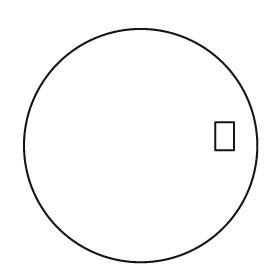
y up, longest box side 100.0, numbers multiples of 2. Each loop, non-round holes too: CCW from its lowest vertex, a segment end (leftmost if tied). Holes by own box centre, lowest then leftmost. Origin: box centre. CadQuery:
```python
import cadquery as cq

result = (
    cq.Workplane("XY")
    .moveTo(0.0, 0.0)
    .circle(50.0)
    .moveTo(32.0, -2.0)
    .lineTo(40.0, -2.0)
    .lineTo(40.0, 10.0)
    .lineTo(32.0, 10.0)
    .close()
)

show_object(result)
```